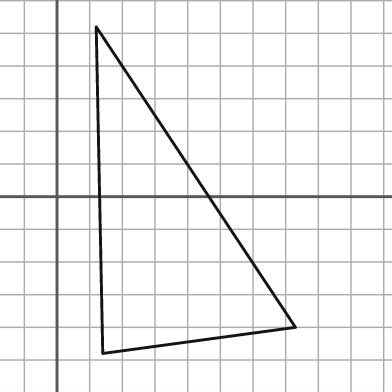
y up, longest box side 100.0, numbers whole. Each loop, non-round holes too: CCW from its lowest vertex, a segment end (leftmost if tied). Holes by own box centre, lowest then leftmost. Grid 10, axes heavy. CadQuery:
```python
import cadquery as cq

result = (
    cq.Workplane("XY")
    .moveTo(14.0, -48.0)
    .lineTo(73.0, -40.0)
    .lineTo(12.0, 52.0)
    .close()
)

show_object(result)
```